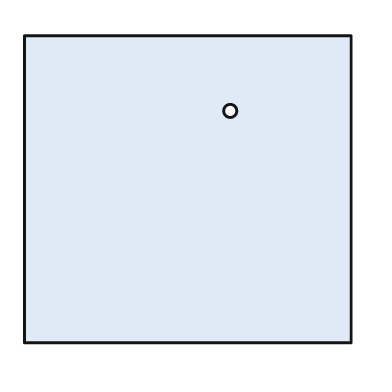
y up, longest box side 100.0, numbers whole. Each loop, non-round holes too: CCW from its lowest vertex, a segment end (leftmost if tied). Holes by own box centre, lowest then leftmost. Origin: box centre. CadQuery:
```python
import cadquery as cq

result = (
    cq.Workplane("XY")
    .moveTo(-50.0, -47.0)
    .lineTo(50.0, -47.0)
    .lineTo(50.0, 47.0)
    .lineTo(-50.0, 47.0)
    .close()
    .moveTo(13.0, 24.0)
    .circle(2.0)
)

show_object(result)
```